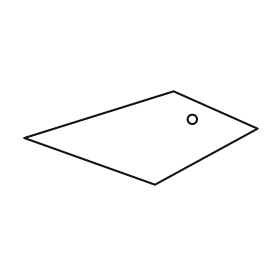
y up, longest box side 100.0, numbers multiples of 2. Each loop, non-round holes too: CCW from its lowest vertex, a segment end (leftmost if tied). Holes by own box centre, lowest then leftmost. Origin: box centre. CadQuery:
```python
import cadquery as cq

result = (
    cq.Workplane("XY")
    .moveTo(6.0, -20.0)
    .lineTo(50.0, 4.0)
    .lineTo(14.0, 20.0)
    .lineTo(-50.0, 0.0)
    .close()
    .moveTo(22.0, 8.0)
    .circle(2.0)
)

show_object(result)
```